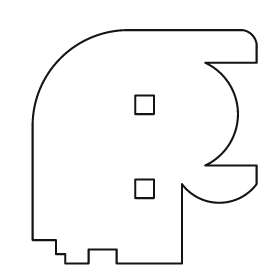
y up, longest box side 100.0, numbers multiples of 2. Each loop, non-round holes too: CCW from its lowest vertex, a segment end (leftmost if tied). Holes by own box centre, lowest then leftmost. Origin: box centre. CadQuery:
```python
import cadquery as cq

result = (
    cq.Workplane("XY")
    .moveTo(-34.0, -50.0)
    .lineTo(-24.0, -50.0)
    .lineTo(-24.0, -44.0)
    .lineTo(-12.0, -44.0)
    .lineTo(-12.0, -50.0)
    .lineTo(16.0, -50.0)
    .lineTo(16.0, -16.0)
    .threePointArc((32.0, -24.0), (48.0, -16.0))
    .lineTo(48.0, -8.0)
    .lineTo(26.0, -8.0)
    .threePointArc((40.0, 14.0), (26.0, 36.0))
    .lineTo(48.0, 36.0)
    .lineTo(48.0, 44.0)
    .threePointArc((46.0, 48.0), (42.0, 50.0))
    .lineTo(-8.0, 50.0)
    .threePointArc((-36.0, 38.0), (-48.0, 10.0))
    .lineTo(-48.0, -40.0)
    .lineTo(-38.0, -40.0)
    .lineTo(-38.0, -46.0)
    .lineTo(-34.0, -46.0)
    .close()
    .moveTo(-4.0, -22.0)
    .lineTo(4.0, -22.0)
    .lineTo(4.0, -14.0)
    .lineTo(-4.0, -14.0)
    .close()
    .moveTo(-4.0, 14.0)
    .lineTo(4.0, 14.0)
    .lineTo(4.0, 22.0)
    .lineTo(-4.0, 22.0)
    .close()
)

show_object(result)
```